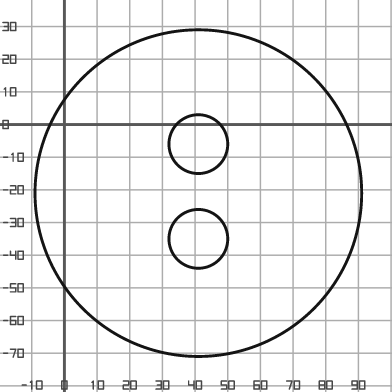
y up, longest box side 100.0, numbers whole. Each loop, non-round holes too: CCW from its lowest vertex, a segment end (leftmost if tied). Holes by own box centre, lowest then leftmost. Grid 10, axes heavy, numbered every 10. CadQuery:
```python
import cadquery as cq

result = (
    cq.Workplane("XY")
    .moveTo(41.0, -21.0)
    .circle(50.0)
    .moveTo(41.0, -35.0)
    .circle(9.0)
    .moveTo(41.0, -6.0)
    .circle(9.0)
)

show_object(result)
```